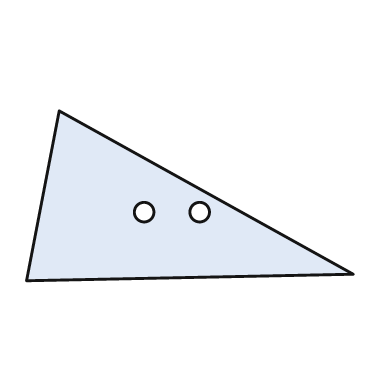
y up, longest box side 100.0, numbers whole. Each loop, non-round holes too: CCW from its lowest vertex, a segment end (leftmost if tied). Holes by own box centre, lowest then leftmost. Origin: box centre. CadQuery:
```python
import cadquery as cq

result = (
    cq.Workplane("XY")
    .moveTo(-50.0, -26.0)
    .lineTo(50.0, -24.0)
    .lineTo(-40.0, 26.0)
    .close()
    .moveTo(-14.0, -5.0)
    .circle(3.0)
    .moveTo(3.0, -5.0)
    .circle(3.0)
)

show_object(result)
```